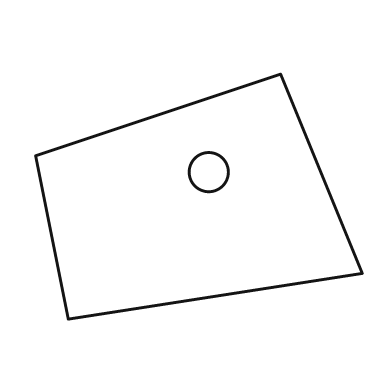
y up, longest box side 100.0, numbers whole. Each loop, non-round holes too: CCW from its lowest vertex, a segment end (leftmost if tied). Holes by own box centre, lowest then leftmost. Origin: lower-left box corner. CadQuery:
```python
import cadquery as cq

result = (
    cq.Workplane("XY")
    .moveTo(10.0, 0.0)
    .lineTo(100.0, 14.0)
    .lineTo(75.0, 75.0)
    .lineTo(0.0, 50.0)
    .close()
    .moveTo(53.0, 45.0)
    .circle(6.0)
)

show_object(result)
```